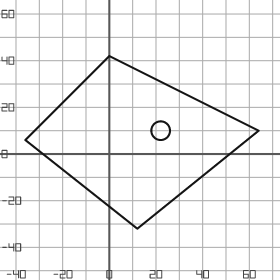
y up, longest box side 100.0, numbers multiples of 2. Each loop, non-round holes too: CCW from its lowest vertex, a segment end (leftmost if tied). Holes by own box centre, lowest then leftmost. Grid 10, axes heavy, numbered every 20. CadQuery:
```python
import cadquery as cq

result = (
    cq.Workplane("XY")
    .moveTo(12.0, -32.0)
    .lineTo(64.0, 10.0)
    .lineTo(0.0, 42.0)
    .lineTo(-36.0, 6.0)
    .close()
    .moveTo(22.0, 10.0)
    .circle(4.0)
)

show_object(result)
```